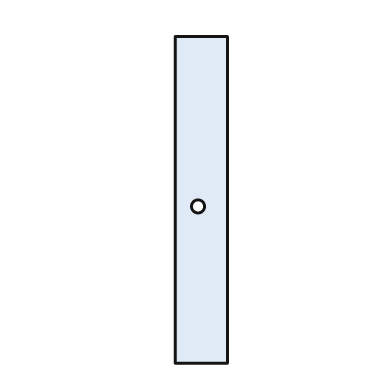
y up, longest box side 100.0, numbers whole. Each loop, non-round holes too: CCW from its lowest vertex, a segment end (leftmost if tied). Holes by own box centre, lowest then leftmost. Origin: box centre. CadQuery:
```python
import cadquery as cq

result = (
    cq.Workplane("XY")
    .moveTo(-8.0, -50.0)
    .lineTo(8.0, -50.0)
    .lineTo(8.0, 50.0)
    .lineTo(-8.0, 50.0)
    .close()
    .moveTo(-1.0, -2.0)
    .circle(2.0)
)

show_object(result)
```